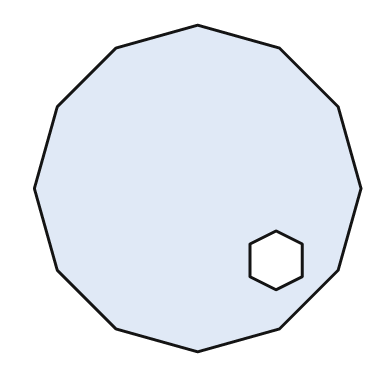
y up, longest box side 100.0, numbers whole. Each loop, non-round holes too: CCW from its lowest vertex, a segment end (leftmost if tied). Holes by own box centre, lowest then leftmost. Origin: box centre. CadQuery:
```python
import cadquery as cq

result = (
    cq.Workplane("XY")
    .moveTo(0.0, -50.0)
    .lineTo(25.0, -43.0)
    .lineTo(43.0, -25.0)
    .lineTo(50.0, 0.0)
    .lineTo(43.0, 25.0)
    .lineTo(25.0, 43.0)
    .lineTo(0.0, 50.0)
    .lineTo(-25.0, 43.0)
    .lineTo(-43.0, 25.0)
    .lineTo(-50.0, 0.0)
    .lineTo(-43.0, -25.0)
    .lineTo(-25.0, -43.0)
    .close()
    .moveTo(24.0, -31.0)
    .lineTo(32.0, -27.0)
    .lineTo(32.0, -17.0)
    .lineTo(24.0, -13.0)
    .lineTo(16.0, -17.0)
    .lineTo(16.0, -27.0)
    .close()
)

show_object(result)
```